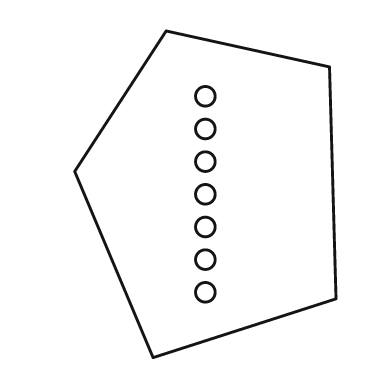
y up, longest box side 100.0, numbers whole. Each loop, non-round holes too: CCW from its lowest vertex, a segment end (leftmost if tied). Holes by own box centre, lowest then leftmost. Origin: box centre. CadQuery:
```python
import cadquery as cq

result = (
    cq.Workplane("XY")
    .moveTo(-16.0, -50.0)
    .lineTo(40.0, -32.0)
    .lineTo(38.0, 39.0)
    .lineTo(-12.0, 50.0)
    .lineTo(-40.0, 7.0)
    .close()
    .moveTo(0.0, -30.0)
    .circle(3.0)
    .moveTo(0.0, -20.0)
    .circle(3.0)
    .moveTo(0.0, -10.0)
    .circle(3.0)
    .moveTo(0.0, 0.0)
    .circle(3.0)
    .moveTo(0.0, 10.0)
    .circle(3.0)
    .moveTo(0.0, 20.0)
    .circle(3.0)
    .moveTo(0.0, 30.0)
    .circle(3.0)
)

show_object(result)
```